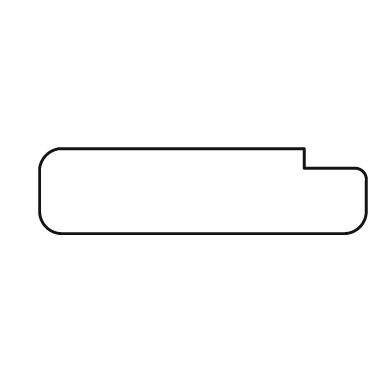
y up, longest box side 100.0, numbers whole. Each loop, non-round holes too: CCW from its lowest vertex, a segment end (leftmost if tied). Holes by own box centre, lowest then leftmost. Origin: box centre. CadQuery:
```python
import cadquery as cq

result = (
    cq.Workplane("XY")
    .moveTo(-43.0, -13.0)
    .lineTo(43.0, -13.0)
    .threePointArc((48.0, -11.0), (50.0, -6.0))
    .lineTo(50.0, 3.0)
    .threePointArc((49.0, 6.0), (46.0, 7.0))
    .lineTo(31.0, 7.0)
    .lineTo(31.0, 13.0)
    .lineTo(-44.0, 13.0)
    .threePointArc((-48.0, 11.0), (-50.0, 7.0))
    .lineTo(-50.0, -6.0)
    .threePointArc((-48.0, -11.0), (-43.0, -13.0))
    .close()
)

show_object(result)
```